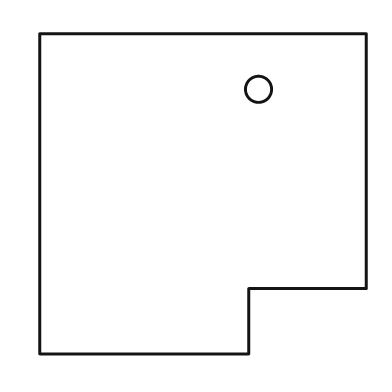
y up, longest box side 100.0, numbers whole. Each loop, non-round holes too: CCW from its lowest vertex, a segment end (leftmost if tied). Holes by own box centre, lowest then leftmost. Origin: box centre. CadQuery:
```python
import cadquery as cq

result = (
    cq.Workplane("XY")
    .moveTo(-50.0, -49.0)
    .lineTo(14.0, -49.0)
    .lineTo(14.0, -29.0)
    .lineTo(50.0, -29.0)
    .lineTo(50.0, 49.0)
    .lineTo(-50.0, 49.0)
    .close()
    .moveTo(17.0, 32.0)
    .circle(4.0)
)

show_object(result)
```